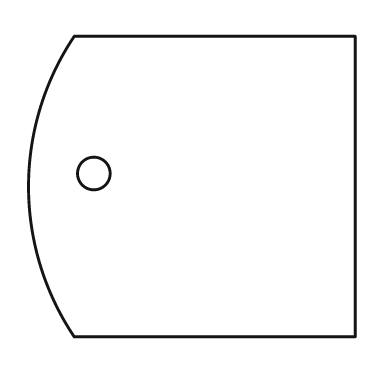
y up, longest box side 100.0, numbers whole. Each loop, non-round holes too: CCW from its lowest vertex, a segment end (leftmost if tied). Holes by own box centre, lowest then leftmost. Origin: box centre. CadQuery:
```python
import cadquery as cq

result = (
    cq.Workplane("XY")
    .moveTo(-36.0, -46.0)
    .lineTo(50.0, -46.0)
    .lineTo(50.0, 46.0)
    .lineTo(-36.0, 46.0)
    .threePointArc((-50.0, 0.0), (-36.0, -46.0))
    .close()
    .moveTo(-30.0, 4.0)
    .circle(5.0)
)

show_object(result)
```